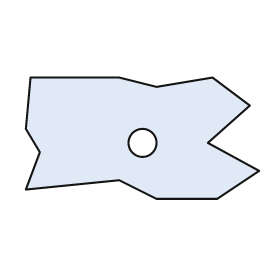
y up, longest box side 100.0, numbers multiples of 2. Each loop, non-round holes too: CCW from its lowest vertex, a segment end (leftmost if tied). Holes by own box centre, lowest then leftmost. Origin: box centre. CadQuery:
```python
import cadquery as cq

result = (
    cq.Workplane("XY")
    .moveTo(6.0, -26.0)
    .lineTo(32.0, -26.0)
    .lineTo(50.0, -14.0)
    .lineTo(28.0, -2.0)
    .lineTo(46.0, 14.0)
    .lineTo(30.0, 26.0)
    .lineTo(6.0, 22.0)
    .lineTo(-10.0, 26.0)
    .lineTo(-48.0, 26.0)
    .lineTo(-50.0, 4.0)
    .lineTo(-44.0, -6.0)
    .lineTo(-50.0, -22.0)
    .lineTo(-10.0, -18.0)
    .close()
    .moveTo(0.0, -2.0)
    .circle(6.0)
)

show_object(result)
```